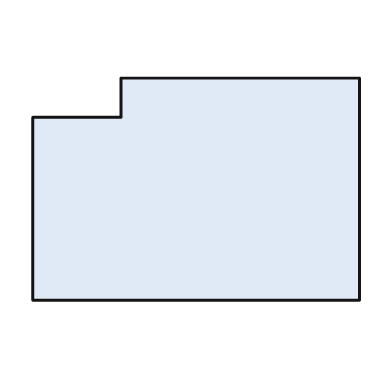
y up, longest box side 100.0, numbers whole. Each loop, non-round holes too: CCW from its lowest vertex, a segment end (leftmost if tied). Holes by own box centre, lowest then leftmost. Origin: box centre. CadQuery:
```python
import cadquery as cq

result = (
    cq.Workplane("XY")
    .moveTo(-50.0, -34.0)
    .lineTo(50.0, -34.0)
    .lineTo(50.0, 34.0)
    .lineTo(-23.0, 34.0)
    .lineTo(-23.0, 22.0)
    .lineTo(-50.0, 22.0)
    .close()
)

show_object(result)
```